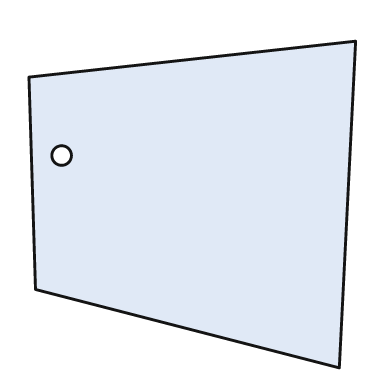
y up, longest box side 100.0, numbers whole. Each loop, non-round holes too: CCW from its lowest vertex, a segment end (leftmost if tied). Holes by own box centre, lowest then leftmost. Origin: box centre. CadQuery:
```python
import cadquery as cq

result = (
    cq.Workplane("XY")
    .moveTo(45.0, -50.0)
    .lineTo(50.0, 50.0)
    .lineTo(-50.0, 39.0)
    .lineTo(-48.0, -26.0)
    .close()
    .moveTo(-40.0, 15.0)
    .circle(3.0)
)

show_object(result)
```